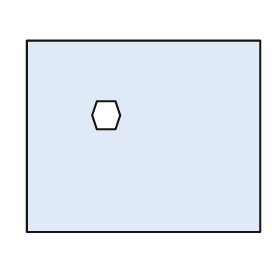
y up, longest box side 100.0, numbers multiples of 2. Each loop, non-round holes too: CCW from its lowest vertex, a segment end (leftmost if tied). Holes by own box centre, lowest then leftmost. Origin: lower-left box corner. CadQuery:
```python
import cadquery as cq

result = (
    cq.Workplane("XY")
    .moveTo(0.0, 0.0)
    .lineTo(100.0, 0.0)
    .lineTo(100.0, 82.0)
    .lineTo(0.0, 82.0)
    .close()
    .moveTo(30.0, 44.0)
    .lineTo(38.0, 44.0)
    .lineTo(40.0, 50.0)
    .lineTo(38.0, 56.0)
    .lineTo(30.0, 56.0)
    .lineTo(28.0, 50.0)
    .close()
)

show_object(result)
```